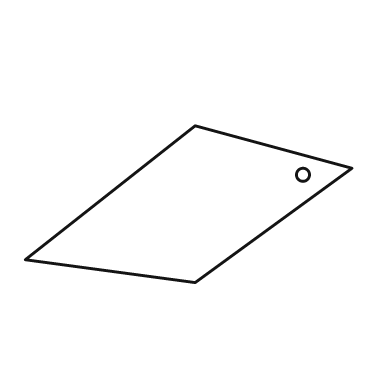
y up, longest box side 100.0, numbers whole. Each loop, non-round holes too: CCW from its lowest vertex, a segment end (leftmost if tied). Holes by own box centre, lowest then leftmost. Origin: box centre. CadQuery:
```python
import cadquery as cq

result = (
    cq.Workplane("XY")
    .moveTo(2.0, -24.0)
    .lineTo(50.0, 11.0)
    .lineTo(2.0, 24.0)
    .lineTo(-50.0, -17.0)
    .close()
    .moveTo(35.0, 9.0)
    .circle(2.0)
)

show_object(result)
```